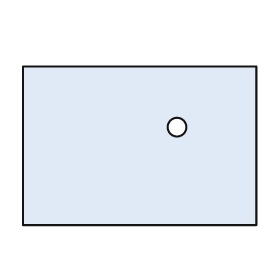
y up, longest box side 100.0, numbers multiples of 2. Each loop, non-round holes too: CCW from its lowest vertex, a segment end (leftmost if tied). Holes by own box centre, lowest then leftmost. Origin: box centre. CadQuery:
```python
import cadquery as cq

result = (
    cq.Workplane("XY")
    .moveTo(-50.0, -34.0)
    .lineTo(50.0, -34.0)
    .lineTo(50.0, 34.0)
    .lineTo(-50.0, 34.0)
    .close()
    .moveTo(16.0, 8.0)
    .circle(4.0)
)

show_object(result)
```